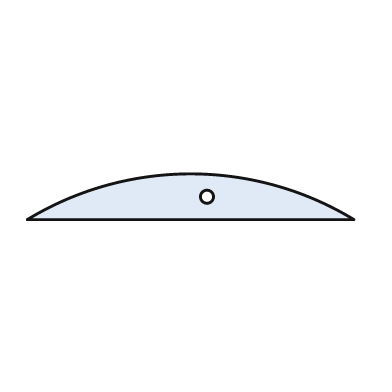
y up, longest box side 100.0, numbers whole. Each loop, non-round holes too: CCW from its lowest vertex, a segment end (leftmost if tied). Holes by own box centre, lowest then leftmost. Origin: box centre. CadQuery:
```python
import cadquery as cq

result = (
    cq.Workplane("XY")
    .moveTo(-50.0, -7.0)
    .lineTo(50.0, -7.0)
    .threePointArc((0.0, 7.0), (-50.0, -7.0))
    .close()
    .moveTo(5.0, 0.0)
    .circle(2.0)
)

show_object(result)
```